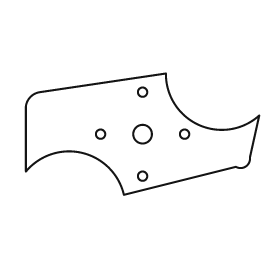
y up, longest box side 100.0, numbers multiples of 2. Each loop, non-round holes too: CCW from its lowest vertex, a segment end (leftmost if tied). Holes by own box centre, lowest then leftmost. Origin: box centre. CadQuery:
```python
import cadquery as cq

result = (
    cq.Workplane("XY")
    .moveTo(-8.0, -26.0)
    .lineTo(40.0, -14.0)
    .threePointArc((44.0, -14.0), (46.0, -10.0))
    .lineTo(50.0, 8.0)
    .threePointArc((24.0, 4.0), (10.0, 26.0))
    .lineTo(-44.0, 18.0)
    .threePointArc((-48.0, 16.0), (-50.0, 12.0))
    .lineTo(-50.0, -16.0)
    .threePointArc((-26.0, -8.0), (-8.0, -26.0))
    .close()
    .moveTo(0.0, -18.0)
    .circle(2.0)
    .moveTo(-18.0, 0.0)
    .circle(2.0)
    .moveTo(0.0, 0.0)
    .circle(4.0)
    .moveTo(18.0, 0.0)
    .circle(2.0)
    .moveTo(0.0, 18.0)
    .circle(2.0)
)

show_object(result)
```